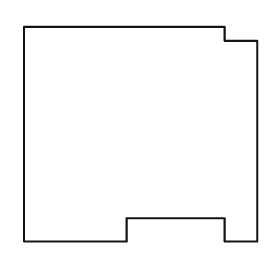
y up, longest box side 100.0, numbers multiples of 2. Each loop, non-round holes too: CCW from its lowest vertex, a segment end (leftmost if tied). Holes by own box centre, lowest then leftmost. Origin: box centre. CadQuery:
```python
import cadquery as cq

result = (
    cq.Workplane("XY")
    .moveTo(-50.0, -46.0)
    .lineTo(-6.0, -46.0)
    .lineTo(-6.0, -36.0)
    .lineTo(36.0, -36.0)
    .lineTo(36.0, -46.0)
    .lineTo(50.0, -46.0)
    .lineTo(50.0, 40.0)
    .lineTo(36.0, 40.0)
    .lineTo(36.0, 46.0)
    .lineTo(-50.0, 46.0)
    .close()
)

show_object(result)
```